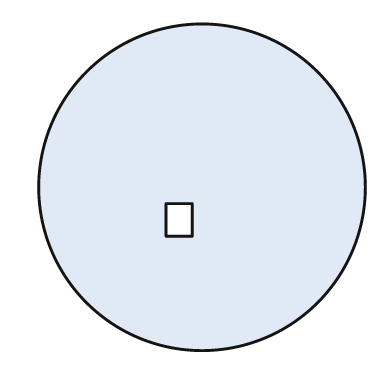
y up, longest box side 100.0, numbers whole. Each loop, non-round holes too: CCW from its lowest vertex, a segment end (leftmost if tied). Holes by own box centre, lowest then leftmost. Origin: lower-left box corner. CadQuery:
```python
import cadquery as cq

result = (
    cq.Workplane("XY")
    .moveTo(50.0, 50.0)
    .circle(50.0)
    .moveTo(39.0, 35.0)
    .lineTo(47.0, 35.0)
    .lineTo(47.0, 45.0)
    .lineTo(39.0, 45.0)
    .close()
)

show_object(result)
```